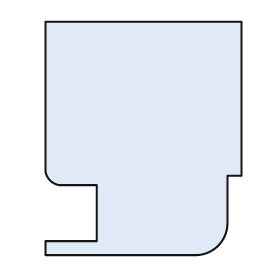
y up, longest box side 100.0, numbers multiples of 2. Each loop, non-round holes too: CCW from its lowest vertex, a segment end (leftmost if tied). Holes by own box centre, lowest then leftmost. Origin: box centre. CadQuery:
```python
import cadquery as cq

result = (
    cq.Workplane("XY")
    .moveTo(-42.0, -50.0)
    .lineTo(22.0, -50.0)
    .threePointArc((32.0, -46.0), (36.0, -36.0))
    .lineTo(36.0, -16.0)
    .lineTo(42.0, -16.0)
    .lineTo(42.0, 50.0)
    .lineTo(-42.0, 50.0)
    .lineTo(-42.0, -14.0)
    .threePointArc((-40.0, -18.0), (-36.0, -20.0))
    .lineTo(-20.0, -20.0)
    .lineTo(-20.0, -44.0)
    .lineTo(-42.0, -44.0)
    .close()
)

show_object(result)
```